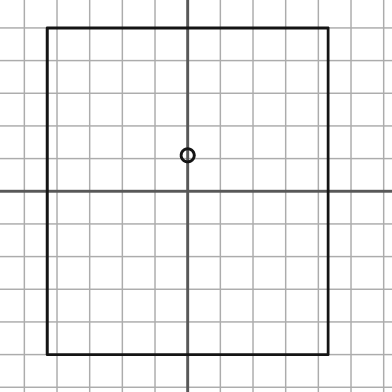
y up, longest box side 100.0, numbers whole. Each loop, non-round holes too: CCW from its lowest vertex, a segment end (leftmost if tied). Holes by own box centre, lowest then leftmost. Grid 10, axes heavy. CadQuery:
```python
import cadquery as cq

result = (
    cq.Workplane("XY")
    .moveTo(-43.0, -50.0)
    .lineTo(43.0, -50.0)
    .lineTo(43.0, 50.0)
    .lineTo(-43.0, 50.0)
    .close()
    .moveTo(0.0, 11.0)
    .circle(2.0)
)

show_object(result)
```